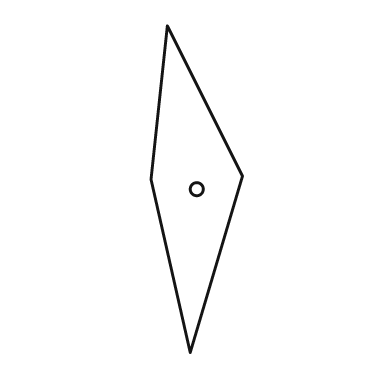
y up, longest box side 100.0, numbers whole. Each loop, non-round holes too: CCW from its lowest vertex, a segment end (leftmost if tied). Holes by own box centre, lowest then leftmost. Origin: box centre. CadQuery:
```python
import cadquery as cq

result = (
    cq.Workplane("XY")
    .moveTo(-2.0, -50.0)
    .lineTo(14.0, 4.0)
    .lineTo(-9.0, 50.0)
    .lineTo(-14.0, 3.0)
    .close()
    .moveTo(0.0, 0.0)
    .circle(2.0)
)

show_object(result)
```